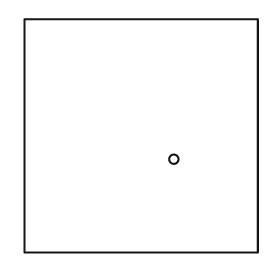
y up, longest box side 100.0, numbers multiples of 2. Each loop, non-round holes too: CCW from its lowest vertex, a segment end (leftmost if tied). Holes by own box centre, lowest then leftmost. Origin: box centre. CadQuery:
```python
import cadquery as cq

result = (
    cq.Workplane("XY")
    .moveTo(-50.0, -50.0)
    .lineTo(50.0, -50.0)
    .lineTo(50.0, 50.0)
    .lineTo(-50.0, 50.0)
    .close()
    .moveTo(14.0, -10.0)
    .circle(2.0)
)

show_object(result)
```